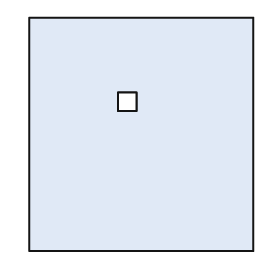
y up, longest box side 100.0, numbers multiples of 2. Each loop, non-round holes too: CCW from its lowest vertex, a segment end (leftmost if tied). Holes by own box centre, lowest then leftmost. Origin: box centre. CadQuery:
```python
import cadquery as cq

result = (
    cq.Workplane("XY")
    .moveTo(-48.0, -50.0)
    .lineTo(48.0, -50.0)
    .lineTo(48.0, 50.0)
    .lineTo(-48.0, 50.0)
    .close()
    .moveTo(-10.0, 10.0)
    .lineTo(-2.0, 10.0)
    .lineTo(-2.0, 18.0)
    .lineTo(-10.0, 18.0)
    .close()
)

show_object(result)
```